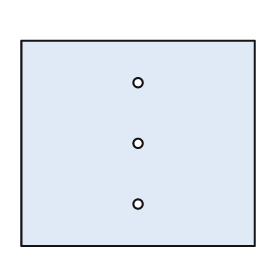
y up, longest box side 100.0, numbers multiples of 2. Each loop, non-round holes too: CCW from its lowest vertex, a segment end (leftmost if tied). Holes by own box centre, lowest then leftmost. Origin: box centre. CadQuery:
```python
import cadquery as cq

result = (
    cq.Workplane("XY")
    .moveTo(-50.0, -44.0)
    .lineTo(50.0, -44.0)
    .lineTo(50.0, 44.0)
    .lineTo(-50.0, 44.0)
    .close()
    .moveTo(0.0, -26.0)
    .circle(2.0)
    .moveTo(0.0, 0.0)
    .circle(2.0)
    .moveTo(0.0, 26.0)
    .circle(2.0)
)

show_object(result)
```